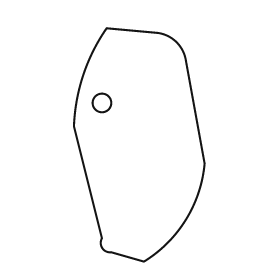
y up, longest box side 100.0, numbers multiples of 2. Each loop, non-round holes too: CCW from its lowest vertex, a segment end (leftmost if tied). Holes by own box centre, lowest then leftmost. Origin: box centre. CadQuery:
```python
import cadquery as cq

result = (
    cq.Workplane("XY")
    .moveTo(2.0, -50.0)
    .threePointArc((20.0, -32.0), (28.0, -8.0))
    .lineTo(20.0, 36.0)
    .threePointArc((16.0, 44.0), (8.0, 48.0))
    .lineTo(-14.0, 50.0)
    .threePointArc((-24.0, 30.0), (-28.0, 8.0))
    .lineTo(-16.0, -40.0)
    .threePointArc((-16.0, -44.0), (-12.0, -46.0))
    .close()
    .moveTo(-16.0, 18.0)
    .circle(4.0)
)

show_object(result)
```